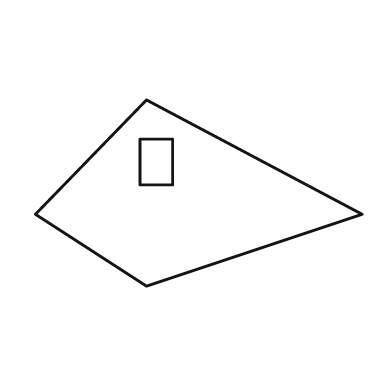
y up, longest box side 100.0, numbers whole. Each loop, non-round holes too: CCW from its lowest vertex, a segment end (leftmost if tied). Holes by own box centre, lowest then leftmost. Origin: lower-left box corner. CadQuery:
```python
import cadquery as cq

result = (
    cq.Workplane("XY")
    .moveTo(34.0, 0.0)
    .lineTo(100.0, 22.0)
    .lineTo(34.0, 57.0)
    .lineTo(0.0, 22.0)
    .close()
    .moveTo(32.0, 31.0)
    .lineTo(42.0, 31.0)
    .lineTo(42.0, 45.0)
    .lineTo(32.0, 45.0)
    .close()
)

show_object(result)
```